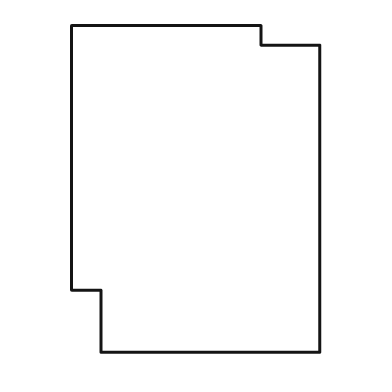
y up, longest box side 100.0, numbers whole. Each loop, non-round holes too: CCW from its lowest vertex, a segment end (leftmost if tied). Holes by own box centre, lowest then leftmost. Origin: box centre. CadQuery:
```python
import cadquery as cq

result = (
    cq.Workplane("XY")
    .moveTo(-29.0, -50.0)
    .lineTo(38.0, -50.0)
    .lineTo(38.0, 44.0)
    .lineTo(20.0, 44.0)
    .lineTo(20.0, 50.0)
    .lineTo(-38.0, 50.0)
    .lineTo(-38.0, -31.0)
    .lineTo(-29.0, -31.0)
    .close()
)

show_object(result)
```